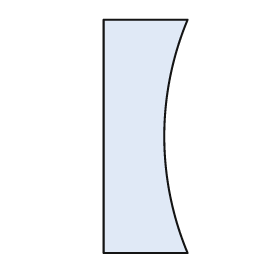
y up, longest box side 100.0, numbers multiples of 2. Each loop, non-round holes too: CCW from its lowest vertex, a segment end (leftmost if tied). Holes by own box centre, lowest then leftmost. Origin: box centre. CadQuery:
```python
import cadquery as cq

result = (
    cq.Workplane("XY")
    .moveTo(-18.0, -50.0)
    .lineTo(18.0, -50.0)
    .threePointArc((8.0, 0.0), (18.0, 50.0))
    .lineTo(-18.0, 50.0)
    .close()
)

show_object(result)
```